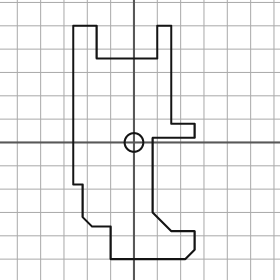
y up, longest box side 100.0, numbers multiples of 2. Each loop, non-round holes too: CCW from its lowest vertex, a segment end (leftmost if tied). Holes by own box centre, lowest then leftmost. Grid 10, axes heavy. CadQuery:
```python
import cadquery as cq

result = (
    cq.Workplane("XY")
    .moveTo(-10.0, -50.0)
    .lineTo(22.0, -50.0)
    .lineTo(26.0, -46.0)
    .lineTo(26.0, -38.0)
    .lineTo(16.0, -38.0)
    .lineTo(8.0, -30.0)
    .lineTo(8.0, 2.0)
    .lineTo(26.0, 2.0)
    .lineTo(26.0, 8.0)
    .lineTo(16.0, 8.0)
    .lineTo(16.0, 50.0)
    .lineTo(10.0, 50.0)
    .lineTo(10.0, 36.0)
    .lineTo(-16.0, 36.0)
    .lineTo(-16.0, 50.0)
    .lineTo(-26.0, 50.0)
    .lineTo(-26.0, -18.0)
    .lineTo(-22.0, -18.0)
    .lineTo(-22.0, -32.0)
    .lineTo(-18.0, -36.0)
    .lineTo(-10.0, -36.0)
    .close()
    .moveTo(0.0, 0.0)
    .circle(4.0)
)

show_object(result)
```